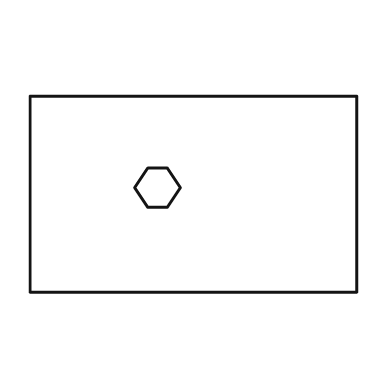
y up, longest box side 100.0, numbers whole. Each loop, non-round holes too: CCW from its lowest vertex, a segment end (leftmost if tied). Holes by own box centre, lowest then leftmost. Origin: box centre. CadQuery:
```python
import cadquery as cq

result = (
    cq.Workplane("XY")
    .moveTo(-50.0, -30.0)
    .lineTo(50.0, -30.0)
    .lineTo(50.0, 30.0)
    .lineTo(-50.0, 30.0)
    .close()
    .moveTo(-14.0, -4.0)
    .lineTo(-8.0, -4.0)
    .lineTo(-4.0, 2.0)
    .lineTo(-8.0, 8.0)
    .lineTo(-14.0, 8.0)
    .lineTo(-18.0, 2.0)
    .close()
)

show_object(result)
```